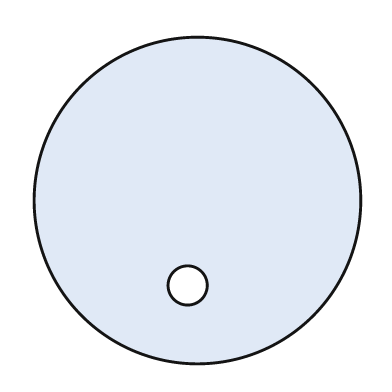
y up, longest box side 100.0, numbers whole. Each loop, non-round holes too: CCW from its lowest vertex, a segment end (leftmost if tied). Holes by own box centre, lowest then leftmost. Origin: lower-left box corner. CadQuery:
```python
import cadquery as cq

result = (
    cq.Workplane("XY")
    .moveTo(50.0, 50.0)
    .circle(50.0)
    .moveTo(47.0, 24.0)
    .circle(6.0)
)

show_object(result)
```